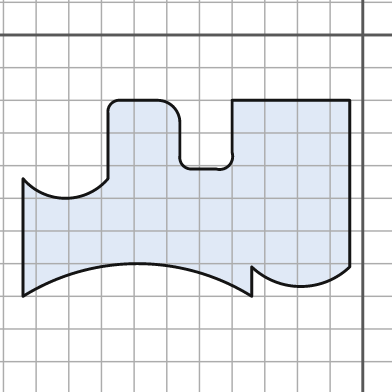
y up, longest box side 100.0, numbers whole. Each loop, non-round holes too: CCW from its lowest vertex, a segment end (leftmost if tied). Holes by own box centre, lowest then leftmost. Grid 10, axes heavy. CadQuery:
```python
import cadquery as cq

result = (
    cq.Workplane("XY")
    .moveTo(-104.0, -80.0)
    .threePointArc((-69.0, -70.0), (-34.0, -80.0))
    .lineTo(-34.0, -71.0)
    .threePointArc((-19.0, -77.0), (-4.0, -71.0))
    .lineTo(-4.0, -20.0)
    .lineTo(-40.0, -20.0)
    .lineTo(-40.0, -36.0)
    .threePointArc((-41.0, -40.0), (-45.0, -41.0))
    .lineTo(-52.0, -41.0)
    .threePointArc((-55.0, -40.0), (-56.0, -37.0))
    .lineTo(-56.0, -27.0)
    .threePointArc((-58.0, -22.0), (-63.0, -20.0))
    .lineTo(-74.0, -20.0)
    .threePointArc((-77.0, -21.0), (-78.0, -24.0))
    .lineTo(-78.0, -44.0)
    .threePointArc((-91.0, -50.0), (-104.0, -44.0))
    .close()
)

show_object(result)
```